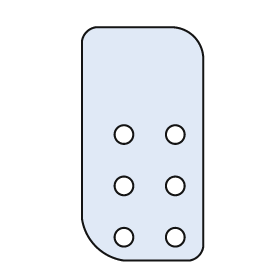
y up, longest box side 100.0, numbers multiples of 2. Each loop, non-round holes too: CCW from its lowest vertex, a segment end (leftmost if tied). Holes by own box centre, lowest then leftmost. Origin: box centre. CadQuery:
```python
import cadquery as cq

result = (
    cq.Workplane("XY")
    .moveTo(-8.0, -50.0)
    .lineTo(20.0, -50.0)
    .threePointArc((24.0, -48.0), (26.0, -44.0))
    .lineTo(26.0, 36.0)
    .threePointArc((22.0, 46.0), (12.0, 50.0))
    .lineTo(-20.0, 50.0)
    .threePointArc((-24.0, 48.0), (-26.0, 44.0))
    .lineTo(-26.0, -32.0)
    .threePointArc((-20.0, -44.0), (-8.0, -50.0))
    .close()
    .moveTo(-8.0, -40.0)
    .circle(4.0)
    .moveTo(14.0, -40.0)
    .circle(4.0)
    .moveTo(-8.0, -18.0)
    .circle(4.0)
    .moveTo(14.0, -18.0)
    .circle(4.0)
    .moveTo(-8.0, 4.0)
    .circle(4.0)
    .moveTo(14.0, 4.0)
    .circle(4.0)
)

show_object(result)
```